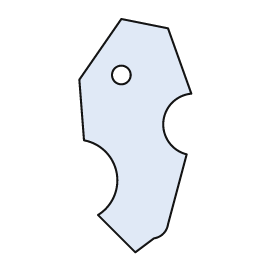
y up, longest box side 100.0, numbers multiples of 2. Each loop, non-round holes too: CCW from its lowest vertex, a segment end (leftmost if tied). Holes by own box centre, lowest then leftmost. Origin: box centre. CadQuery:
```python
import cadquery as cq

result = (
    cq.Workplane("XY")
    .moveTo(0.0, -50.0)
    .lineTo(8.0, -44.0)
    .threePointArc((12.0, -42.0), (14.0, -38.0))
    .lineTo(22.0, -8.0)
    .threePointArc((12.0, 6.0), (24.0, 18.0))
    .lineTo(14.0, 46.0)
    .lineTo(-6.0, 50.0)
    .lineTo(-24.0, 24.0)
    .lineTo(-22.0, -2.0)
    .threePointArc((-8.0, -16.0), (-16.0, -34.0))
    .close()
    .moveTo(-6.0, 26.0)
    .circle(4.0)
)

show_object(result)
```